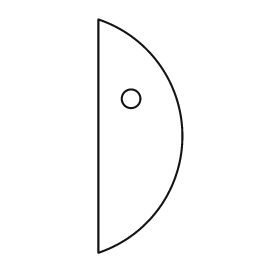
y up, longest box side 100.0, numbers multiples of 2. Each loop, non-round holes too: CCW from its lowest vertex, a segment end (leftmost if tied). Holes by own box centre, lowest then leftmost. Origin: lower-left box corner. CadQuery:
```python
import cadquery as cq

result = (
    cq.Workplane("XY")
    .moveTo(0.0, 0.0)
    .threePointArc((36.0, 50.0), (0.0, 100.0))
    .close()
    .moveTo(14.0, 66.0)
    .circle(4.0)
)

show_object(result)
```